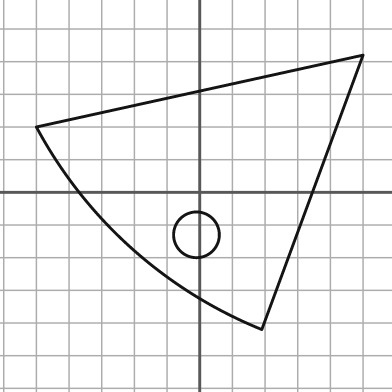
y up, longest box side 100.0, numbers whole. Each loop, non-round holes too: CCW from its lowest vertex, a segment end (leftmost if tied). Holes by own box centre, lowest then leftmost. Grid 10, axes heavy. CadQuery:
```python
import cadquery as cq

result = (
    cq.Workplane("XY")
    .moveTo(19.0, -42.0)
    .lineTo(50.0, 42.0)
    .lineTo(-50.0, 20.0)
    .threePointArc((-21.0, -17.0), (19.0, -42.0))
    .close()
    .moveTo(-1.0, -13.0)
    .circle(7.0)
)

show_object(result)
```